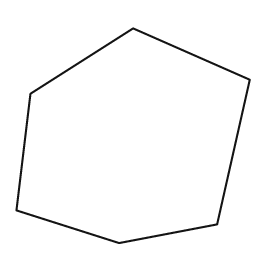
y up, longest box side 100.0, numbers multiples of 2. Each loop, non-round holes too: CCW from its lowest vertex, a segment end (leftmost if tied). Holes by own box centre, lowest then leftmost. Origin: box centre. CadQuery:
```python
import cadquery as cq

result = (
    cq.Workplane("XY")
    .moveTo(-6.0, -46.0)
    .lineTo(36.0, -38.0)
    .lineTo(50.0, 24.0)
    .lineTo(0.0, 46.0)
    .lineTo(-44.0, 18.0)
    .lineTo(-50.0, -32.0)
    .close()
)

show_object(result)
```